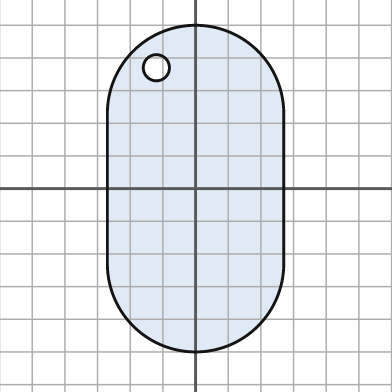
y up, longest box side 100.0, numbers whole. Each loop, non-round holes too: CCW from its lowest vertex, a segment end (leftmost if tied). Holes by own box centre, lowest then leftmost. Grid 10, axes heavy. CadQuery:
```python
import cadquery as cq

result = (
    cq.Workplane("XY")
    .moveTo(-27.0, -23.0)
    .threePointArc((0.0, -50.0), (27.0, -23.0))
    .lineTo(27.0, 23.0)
    .threePointArc((0.0, 50.0), (-27.0, 23.0))
    .close()
    .moveTo(-12.0, 37.0)
    .circle(4.0)
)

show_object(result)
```